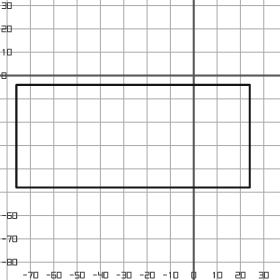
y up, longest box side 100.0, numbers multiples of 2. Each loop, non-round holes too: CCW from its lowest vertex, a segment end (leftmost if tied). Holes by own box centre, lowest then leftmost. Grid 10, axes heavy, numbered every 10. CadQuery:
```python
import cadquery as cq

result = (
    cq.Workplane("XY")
    .moveTo(-76.0, -48.0)
    .lineTo(24.0, -48.0)
    .lineTo(24.0, -4.0)
    .lineTo(-76.0, -4.0)
    .close()
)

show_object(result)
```